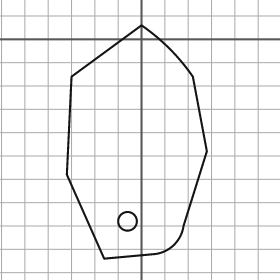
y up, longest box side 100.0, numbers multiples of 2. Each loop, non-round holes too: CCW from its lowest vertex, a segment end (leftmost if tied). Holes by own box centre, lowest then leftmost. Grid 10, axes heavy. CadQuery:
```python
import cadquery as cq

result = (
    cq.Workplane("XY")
    .moveTo(-16.0, -94.0)
    .lineTo(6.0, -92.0)
    .threePointArc((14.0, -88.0), (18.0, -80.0))
    .lineTo(28.0, -48.0)
    .lineTo(22.0, -16.0)
    .threePointArc((12.0, -4.0), (0.0, 6.0))
    .lineTo(-30.0, -16.0)
    .lineTo(-32.0, -58.0)
    .close()
    .moveTo(-6.0, -78.0)
    .circle(4.0)
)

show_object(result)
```